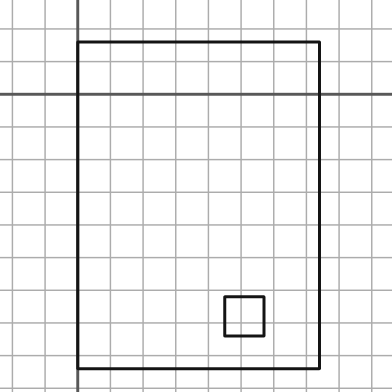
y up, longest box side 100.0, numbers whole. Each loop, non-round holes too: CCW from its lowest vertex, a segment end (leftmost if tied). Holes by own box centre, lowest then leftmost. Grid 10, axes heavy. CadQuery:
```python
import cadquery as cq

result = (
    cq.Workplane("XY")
    .moveTo(0.0, -84.0)
    .lineTo(74.0, -84.0)
    .lineTo(74.0, 16.0)
    .lineTo(0.0, 16.0)
    .close()
    .moveTo(45.0, -74.0)
    .lineTo(57.0, -74.0)
    .lineTo(57.0, -62.0)
    .lineTo(45.0, -62.0)
    .close()
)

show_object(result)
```